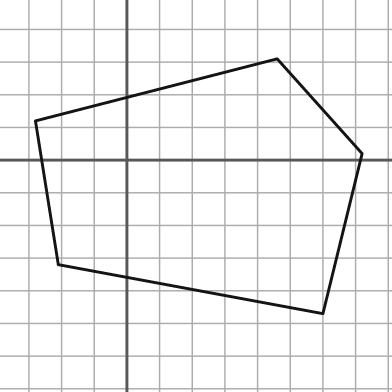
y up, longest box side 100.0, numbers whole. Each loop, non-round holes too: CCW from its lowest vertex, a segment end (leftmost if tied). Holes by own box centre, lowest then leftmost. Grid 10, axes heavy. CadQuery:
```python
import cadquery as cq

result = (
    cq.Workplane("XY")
    .moveTo(60.0, -47.0)
    .lineTo(72.0, 2.0)
    .lineTo(46.0, 31.0)
    .lineTo(-28.0, 12.0)
    .lineTo(-21.0, -32.0)
    .close()
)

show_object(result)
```